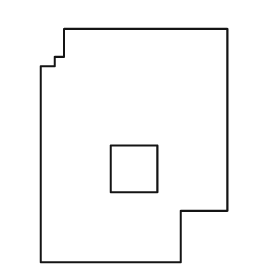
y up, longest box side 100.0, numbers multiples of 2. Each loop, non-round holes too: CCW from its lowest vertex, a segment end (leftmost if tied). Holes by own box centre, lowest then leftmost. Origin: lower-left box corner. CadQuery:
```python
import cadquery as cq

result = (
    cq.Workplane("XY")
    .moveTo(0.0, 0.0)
    .lineTo(60.0, 0.0)
    .lineTo(60.0, 22.0)
    .lineTo(80.0, 22.0)
    .lineTo(80.0, 100.0)
    .lineTo(10.0, 100.0)
    .lineTo(10.0, 88.0)
    .lineTo(6.0, 88.0)
    .lineTo(6.0, 84.0)
    .lineTo(0.0, 84.0)
    .close()
    .moveTo(30.0, 30.0)
    .lineTo(50.0, 30.0)
    .lineTo(50.0, 50.0)
    .lineTo(30.0, 50.0)
    .close()
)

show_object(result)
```